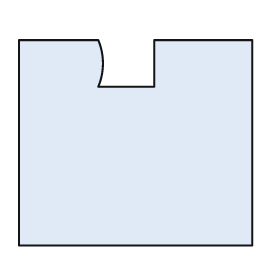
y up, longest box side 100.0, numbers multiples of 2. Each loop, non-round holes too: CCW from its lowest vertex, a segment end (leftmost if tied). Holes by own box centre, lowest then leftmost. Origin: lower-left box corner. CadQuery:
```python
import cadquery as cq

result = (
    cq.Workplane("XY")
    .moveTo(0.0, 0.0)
    .lineTo(100.0, 0.0)
    .lineTo(100.0, 88.0)
    .lineTo(58.0, 88.0)
    .lineTo(58.0, 68.0)
    .lineTo(34.0, 68.0)
    .threePointArc((36.0, 78.0), (34.0, 88.0))
    .lineTo(0.0, 88.0)
    .close()
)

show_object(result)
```